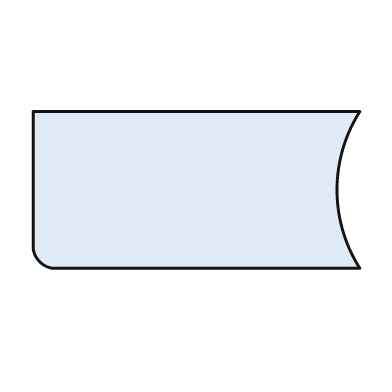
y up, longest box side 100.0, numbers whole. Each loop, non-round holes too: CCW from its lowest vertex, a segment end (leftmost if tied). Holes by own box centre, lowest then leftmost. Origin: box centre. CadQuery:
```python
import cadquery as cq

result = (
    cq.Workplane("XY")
    .moveTo(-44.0, -24.0)
    .lineTo(50.0, -24.0)
    .threePointArc((43.0, 0.0), (50.0, 24.0))
    .lineTo(-50.0, 24.0)
    .lineTo(-50.0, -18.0)
    .threePointArc((-48.0, -22.0), (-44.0, -24.0))
    .close()
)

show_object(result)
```